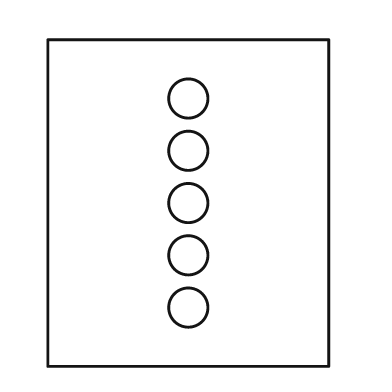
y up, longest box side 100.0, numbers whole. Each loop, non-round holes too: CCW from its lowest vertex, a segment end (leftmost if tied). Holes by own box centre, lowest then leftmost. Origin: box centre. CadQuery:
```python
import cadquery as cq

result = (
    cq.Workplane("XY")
    .moveTo(-43.0, -50.0)
    .lineTo(43.0, -50.0)
    .lineTo(43.0, 50.0)
    .lineTo(-43.0, 50.0)
    .close()
    .moveTo(0.0, -32.0)
    .circle(6.0)
    .moveTo(0.0, -16.0)
    .circle(6.0)
    .moveTo(0.0, 0.0)
    .circle(6.0)
    .moveTo(0.0, 16.0)
    .circle(6.0)
    .moveTo(0.0, 32.0)
    .circle(6.0)
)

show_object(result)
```